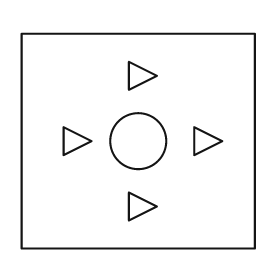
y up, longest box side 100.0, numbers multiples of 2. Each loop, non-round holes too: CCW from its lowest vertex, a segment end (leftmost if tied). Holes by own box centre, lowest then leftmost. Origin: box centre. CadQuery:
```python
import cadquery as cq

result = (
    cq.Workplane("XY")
    .moveTo(-50.0, -46.0)
    .lineTo(50.0, -46.0)
    .lineTo(50.0, 46.0)
    .lineTo(-50.0, 46.0)
    .close()
    .moveTo(-4.0, -34.0)
    .lineTo(8.0, -28.0)
    .lineTo(-4.0, -22.0)
    .close()
    .moveTo(-32.0, -6.0)
    .lineTo(-20.0, 0.0)
    .lineTo(-32.0, 6.0)
    .close()
    .moveTo(0.0, 0.0)
    .circle(12.0)
    .moveTo(24.0, -6.0)
    .lineTo(36.0, 0.0)
    .lineTo(24.0, 6.0)
    .close()
    .moveTo(-4.0, 22.0)
    .lineTo(8.0, 28.0)
    .lineTo(-4.0, 34.0)
    .close()
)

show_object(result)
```